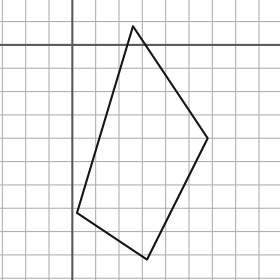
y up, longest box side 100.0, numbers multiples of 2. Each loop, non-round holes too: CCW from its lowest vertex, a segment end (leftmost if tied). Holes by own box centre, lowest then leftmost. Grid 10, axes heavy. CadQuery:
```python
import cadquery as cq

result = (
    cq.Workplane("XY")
    .moveTo(32.0, -92.0)
    .lineTo(58.0, -40.0)
    .lineTo(26.0, 8.0)
    .lineTo(2.0, -72.0)
    .close()
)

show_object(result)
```